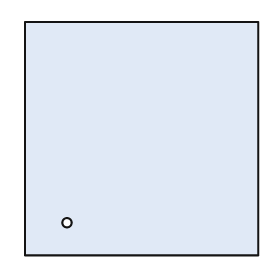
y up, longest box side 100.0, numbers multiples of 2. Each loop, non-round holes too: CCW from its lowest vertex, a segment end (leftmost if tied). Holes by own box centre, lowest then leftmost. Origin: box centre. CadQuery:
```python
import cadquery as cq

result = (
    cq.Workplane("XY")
    .moveTo(-50.0, -50.0)
    .lineTo(50.0, -50.0)
    .lineTo(50.0, 50.0)
    .lineTo(-50.0, 50.0)
    .close()
    .moveTo(-32.0, -36.0)
    .circle(2.0)
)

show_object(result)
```